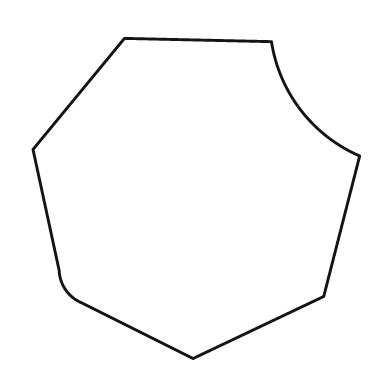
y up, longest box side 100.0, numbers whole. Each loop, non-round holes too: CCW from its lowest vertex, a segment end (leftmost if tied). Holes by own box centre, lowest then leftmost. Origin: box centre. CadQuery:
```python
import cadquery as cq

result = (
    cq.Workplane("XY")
    .moveTo(-1.0, -49.0)
    .lineTo(39.0, -30.0)
    .lineTo(50.0, 13.0)
    .threePointArc((32.0, 27.0), (23.0, 48.0))
    .lineTo(-22.0, 49.0)
    .lineTo(-50.0, 15.0)
    .lineTo(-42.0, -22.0)
    .threePointArc((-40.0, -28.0), (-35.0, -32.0))
    .close()
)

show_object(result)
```